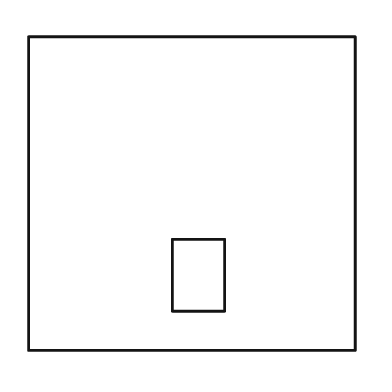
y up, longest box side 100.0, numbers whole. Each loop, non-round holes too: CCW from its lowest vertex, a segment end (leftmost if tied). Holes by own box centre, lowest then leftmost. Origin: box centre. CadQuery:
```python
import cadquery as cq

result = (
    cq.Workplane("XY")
    .moveTo(-50.0, -48.0)
    .lineTo(50.0, -48.0)
    .lineTo(50.0, 48.0)
    .lineTo(-50.0, 48.0)
    .close()
    .moveTo(-6.0, -36.0)
    .lineTo(10.0, -36.0)
    .lineTo(10.0, -14.0)
    .lineTo(-6.0, -14.0)
    .close()
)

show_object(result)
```